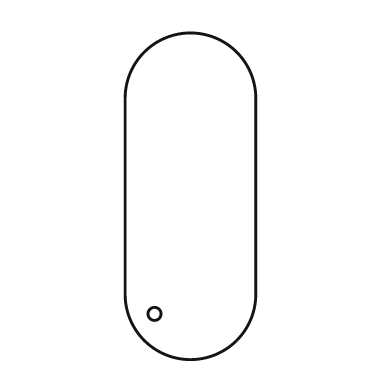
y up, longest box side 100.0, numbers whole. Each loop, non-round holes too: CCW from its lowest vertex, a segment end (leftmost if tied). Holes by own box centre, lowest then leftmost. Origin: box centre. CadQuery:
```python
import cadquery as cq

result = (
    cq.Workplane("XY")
    .moveTo(-20.0, -30.0)
    .threePointArc((0.0, -50.0), (20.0, -30.0))
    .lineTo(20.0, 30.0)
    .threePointArc((0.0, 50.0), (-20.0, 30.0))
    .close()
    .moveTo(-11.0, -36.0)
    .circle(2.0)
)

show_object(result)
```